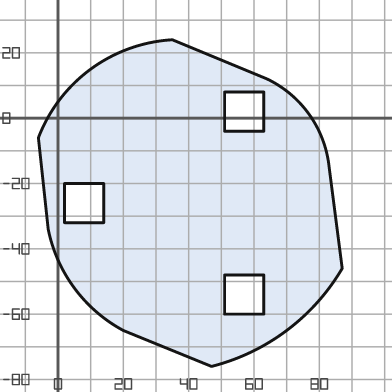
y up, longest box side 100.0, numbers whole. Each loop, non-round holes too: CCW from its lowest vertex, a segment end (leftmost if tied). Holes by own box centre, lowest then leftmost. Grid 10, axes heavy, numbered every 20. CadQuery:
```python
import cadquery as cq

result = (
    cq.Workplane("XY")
    .moveTo(47.0, -76.0)
    .threePointArc((70.0, -65.0), (87.0, -46.0))
    .lineTo(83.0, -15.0)
    .threePointArc((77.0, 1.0), (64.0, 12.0))
    .lineTo(35.0, 24.0)
    .threePointArc((10.0, 15.0), (-6.0, -6.0))
    .lineTo(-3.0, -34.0)
    .threePointArc((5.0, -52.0), (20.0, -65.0))
    .close()
    .moveTo(51.0, -60.0)
    .lineTo(63.0, -60.0)
    .lineTo(63.0, -48.0)
    .lineTo(51.0, -48.0)
    .close()
    .moveTo(2.0, -32.0)
    .lineTo(14.0, -32.0)
    .lineTo(14.0, -20.0)
    .lineTo(2.0, -20.0)
    .close()
    .moveTo(51.0, -4.0)
    .lineTo(63.0, -4.0)
    .lineTo(63.0, 8.0)
    .lineTo(51.0, 8.0)
    .close()
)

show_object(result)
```